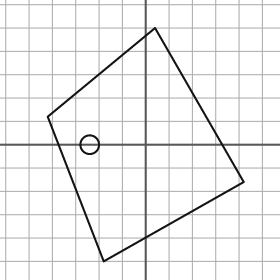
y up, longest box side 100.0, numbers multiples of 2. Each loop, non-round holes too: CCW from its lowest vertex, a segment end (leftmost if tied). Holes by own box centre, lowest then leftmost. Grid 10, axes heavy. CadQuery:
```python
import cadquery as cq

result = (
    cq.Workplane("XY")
    .moveTo(-18.0, -50.0)
    .lineTo(42.0, -16.0)
    .lineTo(4.0, 50.0)
    .lineTo(-42.0, 12.0)
    .close()
    .moveTo(-24.0, 0.0)
    .circle(4.0)
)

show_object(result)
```